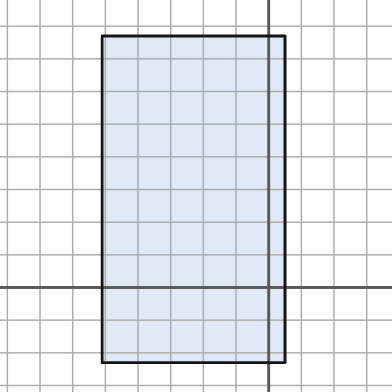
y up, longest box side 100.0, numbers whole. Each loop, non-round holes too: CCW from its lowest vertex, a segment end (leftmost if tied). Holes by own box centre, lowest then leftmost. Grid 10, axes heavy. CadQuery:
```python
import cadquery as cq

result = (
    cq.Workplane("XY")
    .moveTo(-51.0, -23.0)
    .lineTo(5.0, -23.0)
    .lineTo(5.0, 77.0)
    .lineTo(-51.0, 77.0)
    .close()
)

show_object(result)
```